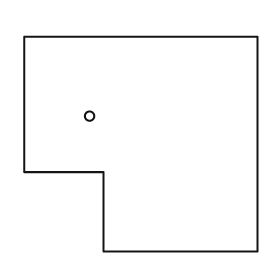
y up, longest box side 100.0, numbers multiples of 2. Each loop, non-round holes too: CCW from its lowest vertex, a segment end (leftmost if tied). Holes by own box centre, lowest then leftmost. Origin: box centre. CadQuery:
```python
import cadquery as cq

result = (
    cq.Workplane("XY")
    .moveTo(-16.0, -46.0)
    .lineTo(50.0, -46.0)
    .lineTo(50.0, 46.0)
    .lineTo(-50.0, 46.0)
    .lineTo(-50.0, -12.0)
    .lineTo(-16.0, -12.0)
    .close()
    .moveTo(-22.0, 12.0)
    .circle(2.0)
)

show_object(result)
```